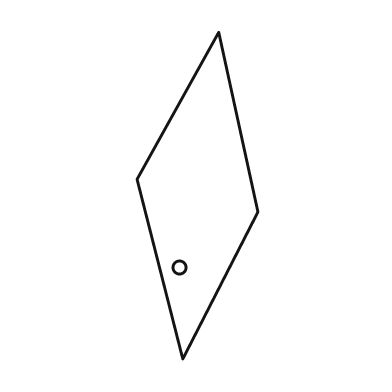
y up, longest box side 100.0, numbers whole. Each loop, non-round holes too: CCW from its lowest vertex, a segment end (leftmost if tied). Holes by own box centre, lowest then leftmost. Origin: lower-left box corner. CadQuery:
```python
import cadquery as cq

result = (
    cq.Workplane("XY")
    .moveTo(14.0, 0.0)
    .lineTo(37.0, 45.0)
    .lineTo(25.0, 100.0)
    .lineTo(0.0, 55.0)
    .close()
    .moveTo(13.0, 28.0)
    .circle(2.0)
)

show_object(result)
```